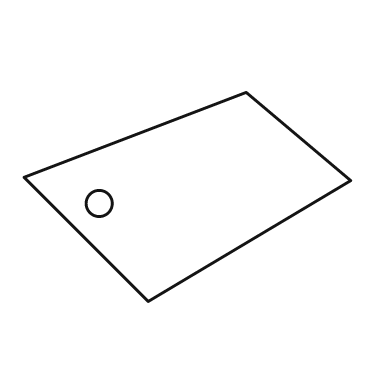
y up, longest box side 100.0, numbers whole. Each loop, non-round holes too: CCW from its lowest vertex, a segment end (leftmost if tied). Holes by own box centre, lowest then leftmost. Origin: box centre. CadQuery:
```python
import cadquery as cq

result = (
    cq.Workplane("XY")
    .moveTo(-12.0, -32.0)
    .lineTo(50.0, 5.0)
    .lineTo(18.0, 32.0)
    .lineTo(-50.0, 6.0)
    .close()
    .moveTo(-27.0, -2.0)
    .circle(4.0)
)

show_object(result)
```